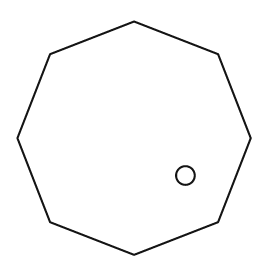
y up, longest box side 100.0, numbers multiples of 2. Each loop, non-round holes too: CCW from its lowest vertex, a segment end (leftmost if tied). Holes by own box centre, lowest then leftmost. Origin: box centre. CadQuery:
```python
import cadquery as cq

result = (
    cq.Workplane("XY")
    .moveTo(0.0, -50.0)
    .lineTo(36.0, -36.0)
    .lineTo(50.0, 0.0)
    .lineTo(36.0, 36.0)
    .lineTo(0.0, 50.0)
    .lineTo(-36.0, 36.0)
    .lineTo(-50.0, 0.0)
    .lineTo(-36.0, -36.0)
    .close()
    .moveTo(22.0, -16.0)
    .circle(4.0)
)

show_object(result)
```